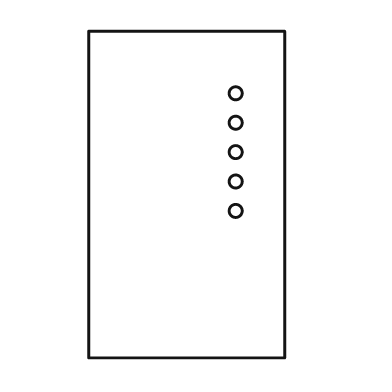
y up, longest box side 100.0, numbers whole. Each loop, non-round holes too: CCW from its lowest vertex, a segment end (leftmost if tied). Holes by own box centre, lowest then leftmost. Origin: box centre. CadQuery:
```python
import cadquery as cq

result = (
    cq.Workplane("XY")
    .moveTo(-30.0, -50.0)
    .lineTo(30.0, -50.0)
    .lineTo(30.0, 50.0)
    .lineTo(-30.0, 50.0)
    .close()
    .moveTo(15.0, -5.0)
    .circle(2.0)
    .moveTo(15.0, 4.0)
    .circle(2.0)
    .moveTo(15.0, 13.0)
    .circle(2.0)
    .moveTo(15.0, 22.0)
    .circle(2.0)
    .moveTo(15.0, 31.0)
    .circle(2.0)
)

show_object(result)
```